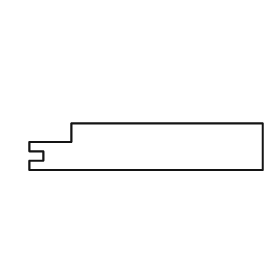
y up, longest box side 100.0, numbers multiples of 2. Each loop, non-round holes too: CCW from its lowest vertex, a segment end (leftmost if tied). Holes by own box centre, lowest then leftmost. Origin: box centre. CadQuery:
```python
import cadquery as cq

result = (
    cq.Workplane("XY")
    .moveTo(-50.0, -10.0)
    .lineTo(50.0, -10.0)
    .lineTo(50.0, 10.0)
    .lineTo(-32.0, 10.0)
    .lineTo(-32.0, 2.0)
    .lineTo(-50.0, 2.0)
    .lineTo(-50.0, -2.0)
    .lineTo(-44.0, -2.0)
    .lineTo(-44.0, -6.0)
    .lineTo(-50.0, -6.0)
    .close()
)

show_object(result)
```